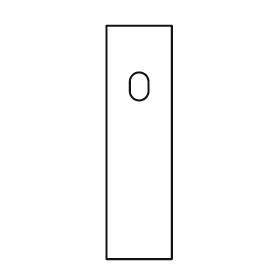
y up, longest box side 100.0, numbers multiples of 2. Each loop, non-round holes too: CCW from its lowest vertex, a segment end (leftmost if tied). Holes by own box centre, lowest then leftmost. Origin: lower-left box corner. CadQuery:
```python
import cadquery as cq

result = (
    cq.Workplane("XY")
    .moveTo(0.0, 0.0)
    .lineTo(28.0, 0.0)
    .lineTo(28.0, 100.0)
    .lineTo(0.0, 100.0)
    .close()
    .moveTo(10.0, 72.0)
    .threePointArc((14.0, 68.0), (18.0, 72.0))
    .lineTo(18.0, 76.0)
    .threePointArc((14.0, 80.0), (10.0, 76.0))
    .close()
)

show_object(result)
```